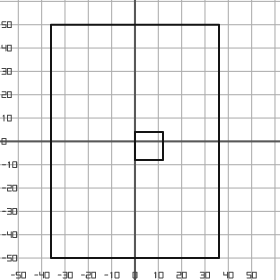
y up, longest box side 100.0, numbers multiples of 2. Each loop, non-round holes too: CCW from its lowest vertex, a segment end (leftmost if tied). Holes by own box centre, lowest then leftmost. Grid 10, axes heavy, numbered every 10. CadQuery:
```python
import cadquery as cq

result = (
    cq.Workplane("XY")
    .moveTo(-36.0, -50.0)
    .lineTo(36.0, -50.0)
    .lineTo(36.0, 50.0)
    .lineTo(-36.0, 50.0)
    .close()
    .moveTo(0.0, -8.0)
    .lineTo(12.0, -8.0)
    .lineTo(12.0, 4.0)
    .lineTo(0.0, 4.0)
    .close()
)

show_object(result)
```